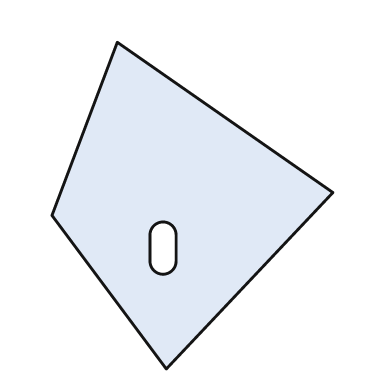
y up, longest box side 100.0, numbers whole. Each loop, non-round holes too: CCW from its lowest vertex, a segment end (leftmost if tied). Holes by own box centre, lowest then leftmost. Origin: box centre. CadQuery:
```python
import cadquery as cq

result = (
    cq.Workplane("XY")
    .moveTo(-8.0, -50.0)
    .lineTo(43.0, 4.0)
    .lineTo(-23.0, 50.0)
    .lineTo(-43.0, -3.0)
    .close()
    .moveTo(-13.0, -17.0)
    .threePointArc((-9.0, -21.0), (-5.0, -17.0))
    .lineTo(-5.0, -9.0)
    .threePointArc((-9.0, -5.0), (-13.0, -9.0))
    .close()
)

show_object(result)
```